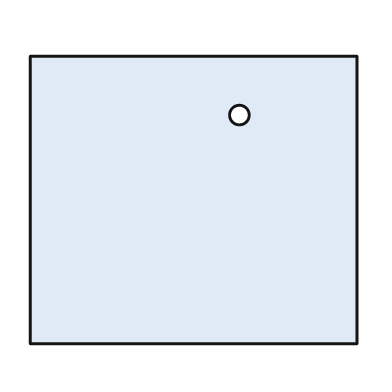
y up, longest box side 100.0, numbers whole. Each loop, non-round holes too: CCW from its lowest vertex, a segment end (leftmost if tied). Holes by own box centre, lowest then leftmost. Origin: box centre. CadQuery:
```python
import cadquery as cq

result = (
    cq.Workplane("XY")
    .moveTo(-50.0, -44.0)
    .lineTo(50.0, -44.0)
    .lineTo(50.0, 44.0)
    .lineTo(-50.0, 44.0)
    .close()
    .moveTo(14.0, 26.0)
    .circle(3.0)
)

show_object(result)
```